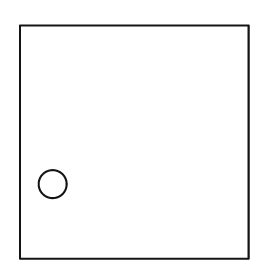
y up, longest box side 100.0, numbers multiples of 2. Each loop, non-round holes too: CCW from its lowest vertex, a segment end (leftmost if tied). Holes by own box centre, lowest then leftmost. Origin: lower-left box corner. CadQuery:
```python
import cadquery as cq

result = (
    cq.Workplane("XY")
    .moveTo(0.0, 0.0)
    .lineTo(98.0, 0.0)
    .lineTo(98.0, 100.0)
    .lineTo(0.0, 100.0)
    .close()
    .moveTo(14.0, 32.0)
    .circle(6.0)
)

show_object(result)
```